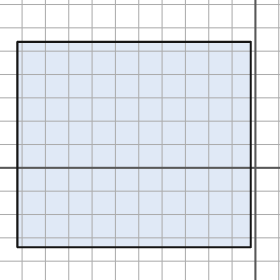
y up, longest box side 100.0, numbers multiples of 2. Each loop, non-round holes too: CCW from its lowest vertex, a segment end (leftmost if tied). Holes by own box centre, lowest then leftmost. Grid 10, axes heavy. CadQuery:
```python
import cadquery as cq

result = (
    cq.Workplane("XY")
    .moveTo(-102.0, -34.0)
    .lineTo(-2.0, -34.0)
    .lineTo(-2.0, 54.0)
    .lineTo(-102.0, 54.0)
    .close()
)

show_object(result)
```